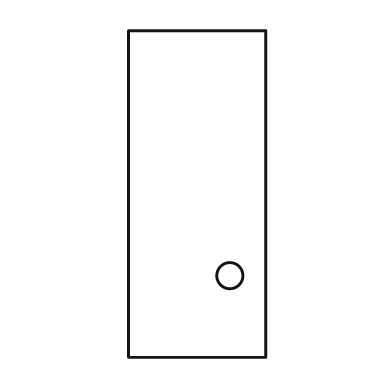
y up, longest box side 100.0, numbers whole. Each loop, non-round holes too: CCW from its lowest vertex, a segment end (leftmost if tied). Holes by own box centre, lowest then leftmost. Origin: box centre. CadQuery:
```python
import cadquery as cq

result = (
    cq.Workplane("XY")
    .moveTo(-21.0, -50.0)
    .lineTo(21.0, -50.0)
    .lineTo(21.0, 50.0)
    .lineTo(-21.0, 50.0)
    .close()
    .moveTo(10.0, -25.0)
    .circle(4.0)
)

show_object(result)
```